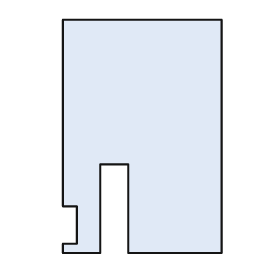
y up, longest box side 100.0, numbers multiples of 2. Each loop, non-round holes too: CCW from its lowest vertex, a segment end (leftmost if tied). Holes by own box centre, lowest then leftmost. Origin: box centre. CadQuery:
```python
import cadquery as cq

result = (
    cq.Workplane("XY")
    .moveTo(-34.0, -50.0)
    .lineTo(-18.0, -50.0)
    .lineTo(-18.0, -12.0)
    .lineTo(-6.0, -12.0)
    .lineTo(-6.0, -50.0)
    .lineTo(34.0, -50.0)
    .lineTo(34.0, 50.0)
    .lineTo(-34.0, 50.0)
    .lineTo(-34.0, -30.0)
    .lineTo(-28.0, -30.0)
    .lineTo(-28.0, -46.0)
    .lineTo(-34.0, -46.0)
    .close()
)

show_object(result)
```